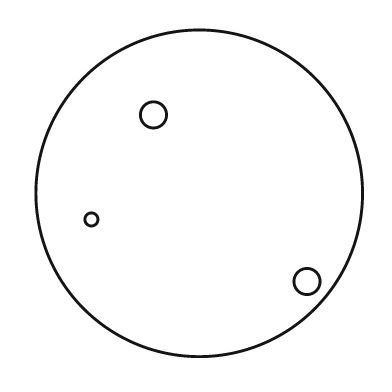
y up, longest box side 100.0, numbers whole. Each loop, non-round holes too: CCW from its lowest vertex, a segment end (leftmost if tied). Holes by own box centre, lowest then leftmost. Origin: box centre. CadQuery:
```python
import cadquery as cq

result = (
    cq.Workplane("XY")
    .moveTo(0.0, 0.0)
    .circle(50.0)
    .moveTo(33.0, -27.0)
    .circle(4.0)
    .moveTo(-33.0, -8.0)
    .circle(2.0)
    .moveTo(-14.0, 24.0)
    .circle(4.0)
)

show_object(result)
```